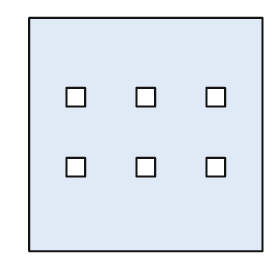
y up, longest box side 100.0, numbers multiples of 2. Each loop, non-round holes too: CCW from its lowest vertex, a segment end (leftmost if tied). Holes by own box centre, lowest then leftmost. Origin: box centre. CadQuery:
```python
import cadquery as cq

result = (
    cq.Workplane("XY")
    .moveTo(-50.0, -50.0)
    .lineTo(50.0, -50.0)
    .lineTo(50.0, 50.0)
    .lineTo(-50.0, 50.0)
    .close()
    .moveTo(-34.0, -18.0)
    .lineTo(-26.0, -18.0)
    .lineTo(-26.0, -10.0)
    .lineTo(-34.0, -10.0)
    .close()
    .moveTo(-4.0, -18.0)
    .lineTo(4.0, -18.0)
    .lineTo(4.0, -10.0)
    .lineTo(-4.0, -10.0)
    .close()
    .moveTo(26.0, -18.0)
    .lineTo(34.0, -18.0)
    .lineTo(34.0, -10.0)
    .lineTo(26.0, -10.0)
    .close()
    .moveTo(-34.0, 12.0)
    .lineTo(-26.0, 12.0)
    .lineTo(-26.0, 20.0)
    .lineTo(-34.0, 20.0)
    .close()
    .moveTo(-4.0, 12.0)
    .lineTo(4.0, 12.0)
    .lineTo(4.0, 20.0)
    .lineTo(-4.0, 20.0)
    .close()
    .moveTo(26.0, 12.0)
    .lineTo(34.0, 12.0)
    .lineTo(34.0, 20.0)
    .lineTo(26.0, 20.0)
    .close()
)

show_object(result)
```